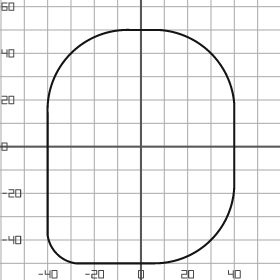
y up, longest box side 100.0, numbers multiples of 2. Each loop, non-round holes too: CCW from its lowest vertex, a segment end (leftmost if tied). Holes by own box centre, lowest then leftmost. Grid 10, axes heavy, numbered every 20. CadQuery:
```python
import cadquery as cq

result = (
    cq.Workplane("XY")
    .moveTo(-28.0, -50.0)
    .lineTo(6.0, -50.0)
    .threePointArc((30.0, -40.0), (40.0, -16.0))
    .lineTo(40.0, 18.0)
    .threePointArc((30.0, 40.0), (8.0, 50.0))
    .lineTo(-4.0, 50.0)
    .threePointArc((-30.0, 40.0), (-40.0, 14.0))
    .lineTo(-40.0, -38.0)
    .threePointArc((-36.0, -46.0), (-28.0, -50.0))
    .close()
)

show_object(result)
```